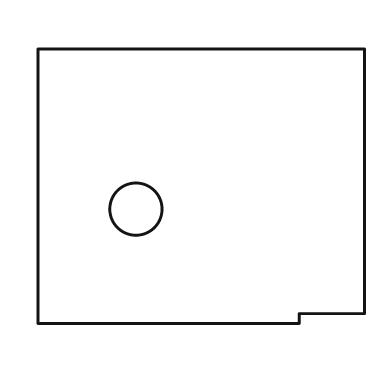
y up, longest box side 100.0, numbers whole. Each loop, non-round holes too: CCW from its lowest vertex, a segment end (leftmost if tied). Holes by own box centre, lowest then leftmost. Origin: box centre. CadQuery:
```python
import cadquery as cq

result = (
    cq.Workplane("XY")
    .moveTo(-50.0, -42.0)
    .lineTo(30.0, -42.0)
    .lineTo(30.0, -39.0)
    .lineTo(50.0, -39.0)
    .lineTo(50.0, 42.0)
    .lineTo(-50.0, 42.0)
    .close()
    .moveTo(-20.0, -7.0)
    .circle(8.0)
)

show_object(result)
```